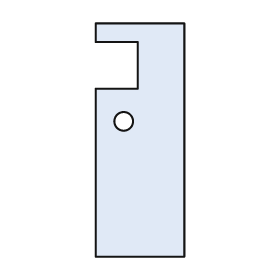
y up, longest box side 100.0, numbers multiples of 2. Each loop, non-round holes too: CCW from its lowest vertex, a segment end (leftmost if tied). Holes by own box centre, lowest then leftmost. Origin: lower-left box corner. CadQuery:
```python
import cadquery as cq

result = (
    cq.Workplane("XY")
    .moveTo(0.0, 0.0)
    .lineTo(38.0, 0.0)
    .lineTo(38.0, 100.0)
    .lineTo(0.0, 100.0)
    .lineTo(0.0, 92.0)
    .lineTo(18.0, 92.0)
    .lineTo(18.0, 72.0)
    .lineTo(0.0, 72.0)
    .close()
    .moveTo(12.0, 58.0)
    .circle(4.0)
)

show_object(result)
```